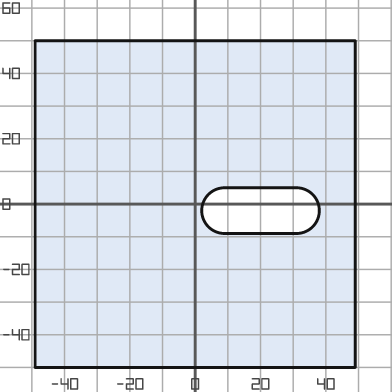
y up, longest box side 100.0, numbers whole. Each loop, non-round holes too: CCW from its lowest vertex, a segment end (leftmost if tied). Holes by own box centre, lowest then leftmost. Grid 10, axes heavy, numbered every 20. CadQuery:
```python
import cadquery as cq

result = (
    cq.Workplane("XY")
    .moveTo(-49.0, -50.0)
    .lineTo(49.0, -50.0)
    .lineTo(49.0, 50.0)
    .lineTo(-49.0, 50.0)
    .close()
    .moveTo(9.0, -9.0)
    .lineTo(31.0, -9.0)
    .threePointArc((38.0, -2.0), (31.0, 5.0))
    .lineTo(9.0, 5.0)
    .threePointArc((2.0, -2.0), (9.0, -9.0))
    .close()
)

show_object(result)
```